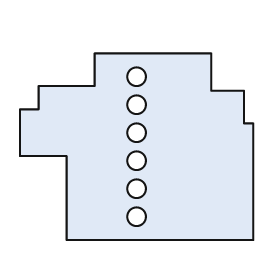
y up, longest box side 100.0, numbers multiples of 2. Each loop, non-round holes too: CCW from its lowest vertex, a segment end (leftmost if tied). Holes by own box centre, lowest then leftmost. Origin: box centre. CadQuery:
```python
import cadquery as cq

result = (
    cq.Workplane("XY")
    .moveTo(-30.0, -40.0)
    .lineTo(50.0, -40.0)
    .lineTo(50.0, 10.0)
    .lineTo(46.0, 10.0)
    .lineTo(46.0, 24.0)
    .lineTo(32.0, 24.0)
    .lineTo(32.0, 40.0)
    .lineTo(-18.0, 40.0)
    .lineTo(-18.0, 26.0)
    .lineTo(-42.0, 26.0)
    .lineTo(-42.0, 16.0)
    .lineTo(-50.0, 16.0)
    .lineTo(-50.0, -4.0)
    .lineTo(-30.0, -4.0)
    .close()
    .moveTo(0.0, -30.0)
    .circle(4.0)
    .moveTo(0.0, -18.0)
    .circle(4.0)
    .moveTo(0.0, -6.0)
    .circle(4.0)
    .moveTo(0.0, 6.0)
    .circle(4.0)
    .moveTo(0.0, 18.0)
    .circle(4.0)
    .moveTo(0.0, 30.0)
    .circle(4.0)
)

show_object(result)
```